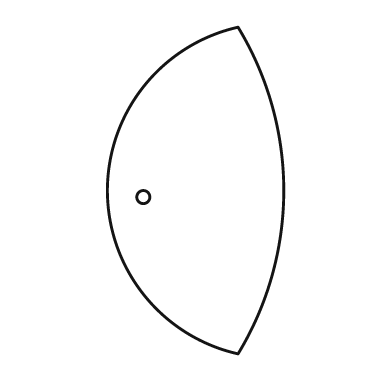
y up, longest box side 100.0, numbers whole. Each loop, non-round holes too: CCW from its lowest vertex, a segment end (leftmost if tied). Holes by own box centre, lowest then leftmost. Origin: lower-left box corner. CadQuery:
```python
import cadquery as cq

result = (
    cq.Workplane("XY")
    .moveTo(40.0, 0.0)
    .threePointArc((54.0, 50.0), (40.0, 100.0))
    .threePointArc((0.0, 50.0), (40.0, 0.0))
    .close()
    .moveTo(11.0, 48.0)
    .circle(2.0)
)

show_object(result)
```